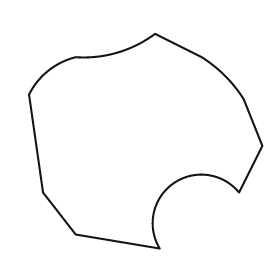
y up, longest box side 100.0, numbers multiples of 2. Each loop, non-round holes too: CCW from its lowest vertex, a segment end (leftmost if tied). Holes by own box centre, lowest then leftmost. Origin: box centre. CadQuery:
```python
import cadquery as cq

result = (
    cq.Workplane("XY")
    .moveTo(6.0, -46.0)
    .threePointArc((12.0, -18.0), (40.0, -22.0))
    .lineTo(50.0, -2.0)
    .lineTo(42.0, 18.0)
    .threePointArc((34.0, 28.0), (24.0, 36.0))
    .lineTo(4.0, 46.0)
    .threePointArc((-12.0, 38.0), (-30.0, 36.0))
    .threePointArc((-42.0, 30.0), (-50.0, 20.0))
    .lineTo(-44.0, -22.0)
    .lineTo(-30.0, -40.0)
    .close()
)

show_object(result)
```